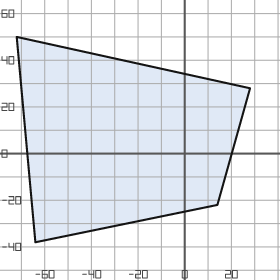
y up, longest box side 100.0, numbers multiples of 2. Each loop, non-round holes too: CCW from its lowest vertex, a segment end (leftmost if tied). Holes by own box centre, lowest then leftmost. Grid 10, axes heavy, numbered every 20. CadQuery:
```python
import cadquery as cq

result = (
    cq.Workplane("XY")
    .moveTo(-64.0, -38.0)
    .lineTo(14.0, -22.0)
    .lineTo(28.0, 28.0)
    .lineTo(-72.0, 50.0)
    .close()
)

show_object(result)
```